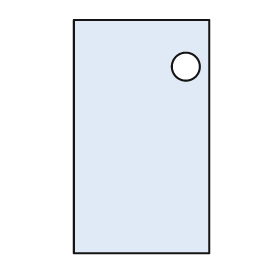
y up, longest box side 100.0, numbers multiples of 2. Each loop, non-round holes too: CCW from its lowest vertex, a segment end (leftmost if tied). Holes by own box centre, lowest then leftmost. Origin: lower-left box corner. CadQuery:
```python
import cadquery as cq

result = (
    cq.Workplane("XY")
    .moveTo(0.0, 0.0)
    .lineTo(58.0, 0.0)
    .lineTo(58.0, 100.0)
    .lineTo(0.0, 100.0)
    .close()
    .moveTo(48.0, 80.0)
    .circle(6.0)
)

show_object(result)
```